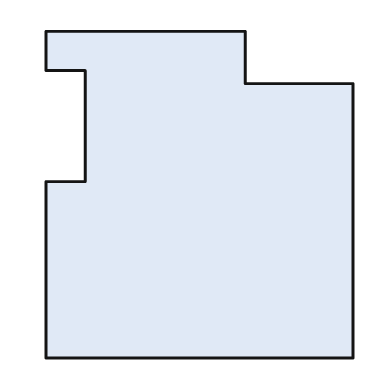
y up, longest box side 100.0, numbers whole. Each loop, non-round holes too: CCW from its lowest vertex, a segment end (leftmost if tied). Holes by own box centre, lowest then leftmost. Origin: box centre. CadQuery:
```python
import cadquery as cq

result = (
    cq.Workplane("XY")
    .moveTo(-47.0, -50.0)
    .lineTo(47.0, -50.0)
    .lineTo(47.0, 34.0)
    .lineTo(14.0, 34.0)
    .lineTo(14.0, 50.0)
    .lineTo(-47.0, 50.0)
    .lineTo(-47.0, 38.0)
    .lineTo(-35.0, 38.0)
    .lineTo(-35.0, 4.0)
    .lineTo(-47.0, 4.0)
    .close()
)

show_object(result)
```